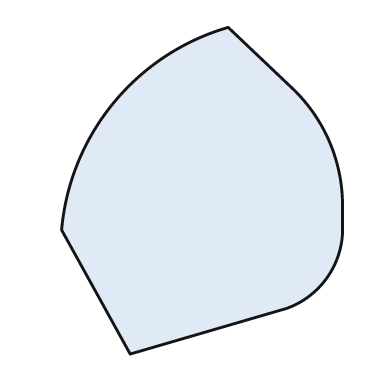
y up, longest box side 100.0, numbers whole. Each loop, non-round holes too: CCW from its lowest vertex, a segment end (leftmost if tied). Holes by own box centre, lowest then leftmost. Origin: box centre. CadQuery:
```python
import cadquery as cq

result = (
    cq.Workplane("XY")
    .moveTo(-22.0, -50.0)
    .lineTo(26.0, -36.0)
    .threePointArc((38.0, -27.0), (43.0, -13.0))
    .lineTo(43.0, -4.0)
    .threePointArc((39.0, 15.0), (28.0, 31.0))
    .lineTo(8.0, 50.0)
    .threePointArc((-27.0, 27.0), (-43.0, -12.0))
    .close()
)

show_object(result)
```